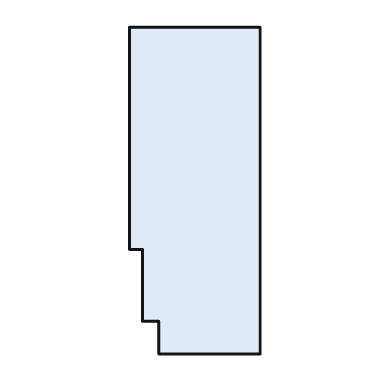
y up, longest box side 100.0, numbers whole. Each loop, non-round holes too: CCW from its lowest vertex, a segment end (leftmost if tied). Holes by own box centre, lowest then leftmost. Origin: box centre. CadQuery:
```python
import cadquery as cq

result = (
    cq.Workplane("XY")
    .moveTo(-11.0, -50.0)
    .lineTo(20.0, -50.0)
    .lineTo(20.0, 50.0)
    .lineTo(-20.0, 50.0)
    .lineTo(-20.0, -18.0)
    .lineTo(-16.0, -18.0)
    .lineTo(-16.0, -40.0)
    .lineTo(-11.0, -40.0)
    .close()
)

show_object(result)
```